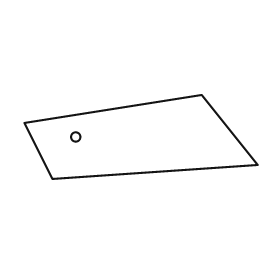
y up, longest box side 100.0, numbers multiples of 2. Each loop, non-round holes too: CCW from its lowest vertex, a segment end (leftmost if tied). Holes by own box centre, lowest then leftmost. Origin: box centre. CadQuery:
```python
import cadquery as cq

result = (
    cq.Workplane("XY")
    .moveTo(-38.0, -18.0)
    .lineTo(50.0, -12.0)
    .lineTo(26.0, 18.0)
    .lineTo(-50.0, 6.0)
    .close()
    .moveTo(-28.0, 0.0)
    .circle(2.0)
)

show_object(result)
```